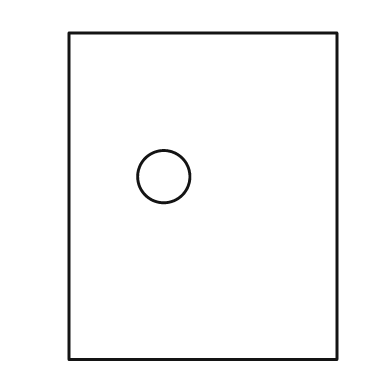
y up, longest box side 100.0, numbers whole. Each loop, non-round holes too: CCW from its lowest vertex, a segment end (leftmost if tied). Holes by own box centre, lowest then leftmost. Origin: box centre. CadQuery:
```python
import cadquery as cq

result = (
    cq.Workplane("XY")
    .moveTo(-41.0, -50.0)
    .lineTo(41.0, -50.0)
    .lineTo(41.0, 50.0)
    .lineTo(-41.0, 50.0)
    .close()
    .moveTo(-12.0, 6.0)
    .circle(8.0)
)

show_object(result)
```